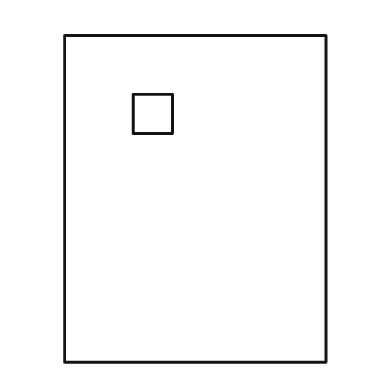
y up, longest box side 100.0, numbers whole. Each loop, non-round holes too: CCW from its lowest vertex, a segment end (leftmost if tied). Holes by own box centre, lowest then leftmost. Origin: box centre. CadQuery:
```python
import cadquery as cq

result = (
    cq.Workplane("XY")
    .moveTo(-40.0, -50.0)
    .lineTo(40.0, -50.0)
    .lineTo(40.0, 50.0)
    .lineTo(-40.0, 50.0)
    .close()
    .moveTo(-19.0, 20.0)
    .lineTo(-7.0, 20.0)
    .lineTo(-7.0, 32.0)
    .lineTo(-19.0, 32.0)
    .close()
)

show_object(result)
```